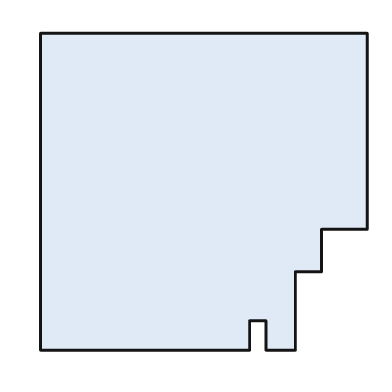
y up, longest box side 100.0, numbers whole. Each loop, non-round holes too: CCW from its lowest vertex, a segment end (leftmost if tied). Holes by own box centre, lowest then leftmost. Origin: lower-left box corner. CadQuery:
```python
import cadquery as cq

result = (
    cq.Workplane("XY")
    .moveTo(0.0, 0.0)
    .lineTo(64.0, 0.0)
    .lineTo(64.0, 9.0)
    .lineTo(69.0, 9.0)
    .lineTo(69.0, 0.0)
    .lineTo(78.0, 0.0)
    .lineTo(78.0, 24.0)
    .lineTo(86.0, 24.0)
    .lineTo(86.0, 37.0)
    .lineTo(100.0, 37.0)
    .lineTo(100.0, 97.0)
    .lineTo(0.0, 97.0)
    .close()
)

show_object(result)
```